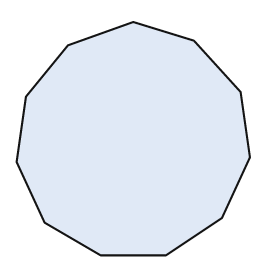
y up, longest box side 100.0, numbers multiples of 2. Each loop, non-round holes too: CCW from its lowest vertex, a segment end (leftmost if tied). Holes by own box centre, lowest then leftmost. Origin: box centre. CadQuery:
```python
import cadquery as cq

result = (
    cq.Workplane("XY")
    .moveTo(-14.0, -50.0)
    .lineTo(14.0, -50.0)
    .lineTo(38.0, -34.0)
    .lineTo(50.0, -8.0)
    .lineTo(46.0, 20.0)
    .lineTo(26.0, 42.0)
    .lineTo(0.0, 50.0)
    .lineTo(-28.0, 40.0)
    .lineTo(-46.0, 18.0)
    .lineTo(-50.0, -10.0)
    .lineTo(-38.0, -36.0)
    .close()
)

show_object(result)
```